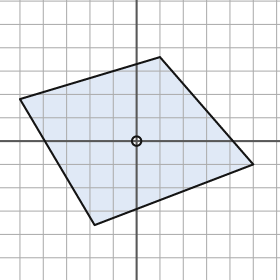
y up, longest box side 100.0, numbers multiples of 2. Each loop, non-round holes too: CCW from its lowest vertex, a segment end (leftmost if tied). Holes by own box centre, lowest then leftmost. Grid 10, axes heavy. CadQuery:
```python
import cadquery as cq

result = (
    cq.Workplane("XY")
    .moveTo(-18.0, -36.0)
    .lineTo(50.0, -10.0)
    .lineTo(10.0, 36.0)
    .lineTo(-50.0, 18.0)
    .close()
    .moveTo(0.0, 0.0)
    .circle(2.0)
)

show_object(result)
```